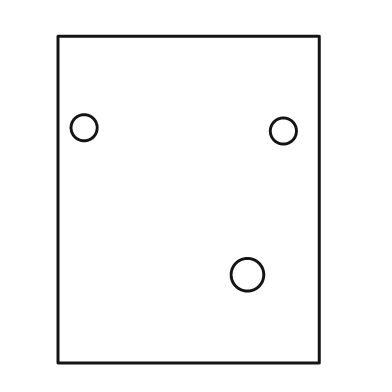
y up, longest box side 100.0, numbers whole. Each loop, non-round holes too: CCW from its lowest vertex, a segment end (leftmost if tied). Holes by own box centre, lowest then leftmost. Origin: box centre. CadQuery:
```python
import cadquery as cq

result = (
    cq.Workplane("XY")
    .moveTo(-40.0, -50.0)
    .lineTo(40.0, -50.0)
    .lineTo(40.0, 50.0)
    .lineTo(-40.0, 50.0)
    .close()
    .moveTo(18.0, -23.0)
    .circle(5.0)
    .moveTo(29.0, 21.0)
    .circle(4.0)
    .moveTo(-32.0, 22.0)
    .circle(4.0)
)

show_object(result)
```